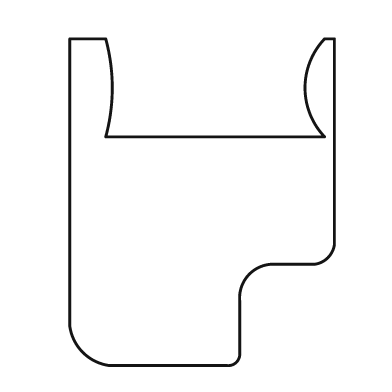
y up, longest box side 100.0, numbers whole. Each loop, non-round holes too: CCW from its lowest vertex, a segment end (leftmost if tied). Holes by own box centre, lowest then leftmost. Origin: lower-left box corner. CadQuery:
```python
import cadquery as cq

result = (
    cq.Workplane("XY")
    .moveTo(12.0, 0.0)
    .lineTo(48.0, 0.0)
    .threePointArc((51.0, 1.0), (52.0, 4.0))
    .lineTo(52.0, 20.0)
    .threePointArc((55.0, 28.0), (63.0, 31.0))
    .lineTo(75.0, 31.0)
    .threePointArc((79.0, 33.0), (81.0, 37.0))
    .lineTo(81.0, 100.0)
    .lineTo(78.0, 100.0)
    .threePointArc((72.0, 85.0), (78.0, 70.0))
    .lineTo(11.0, 70.0)
    .threePointArc((13.0, 85.0), (11.0, 100.0))
    .lineTo(0.0, 100.0)
    .lineTo(0.0, 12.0)
    .threePointArc((4.0, 4.0), (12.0, 0.0))
    .close()
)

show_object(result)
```